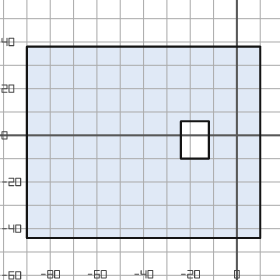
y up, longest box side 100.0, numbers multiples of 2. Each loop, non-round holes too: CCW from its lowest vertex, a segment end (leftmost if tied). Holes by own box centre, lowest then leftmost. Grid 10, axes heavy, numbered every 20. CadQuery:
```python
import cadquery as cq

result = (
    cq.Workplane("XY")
    .moveTo(-90.0, -44.0)
    .lineTo(10.0, -44.0)
    .lineTo(10.0, 38.0)
    .lineTo(-90.0, 38.0)
    .close()
    .moveTo(-24.0, -10.0)
    .lineTo(-12.0, -10.0)
    .lineTo(-12.0, 6.0)
    .lineTo(-24.0, 6.0)
    .close()
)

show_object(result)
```